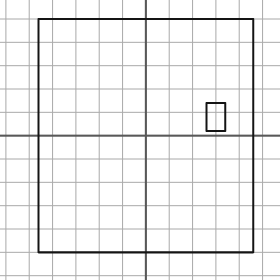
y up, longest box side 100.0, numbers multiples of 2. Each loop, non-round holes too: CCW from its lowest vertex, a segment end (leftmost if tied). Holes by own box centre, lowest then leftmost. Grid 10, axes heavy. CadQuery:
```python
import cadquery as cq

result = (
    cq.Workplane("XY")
    .moveTo(-46.0, -50.0)
    .lineTo(46.0, -50.0)
    .lineTo(46.0, 50.0)
    .lineTo(-46.0, 50.0)
    .close()
    .moveTo(26.0, 2.0)
    .lineTo(34.0, 2.0)
    .lineTo(34.0, 14.0)
    .lineTo(26.0, 14.0)
    .close()
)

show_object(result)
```